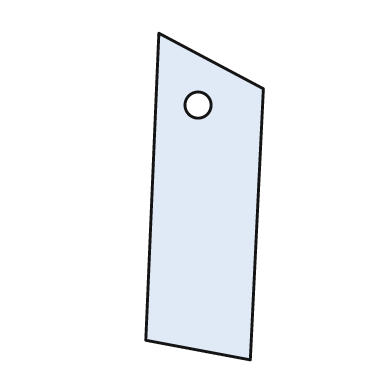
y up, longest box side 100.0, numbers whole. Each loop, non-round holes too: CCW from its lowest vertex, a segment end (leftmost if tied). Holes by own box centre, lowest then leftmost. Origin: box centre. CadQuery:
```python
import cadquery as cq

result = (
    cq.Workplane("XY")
    .moveTo(14.0, -50.0)
    .lineTo(18.0, 33.0)
    .lineTo(-14.0, 50.0)
    .lineTo(-18.0, -44.0)
    .close()
    .moveTo(-2.0, 28.0)
    .circle(4.0)
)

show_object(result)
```